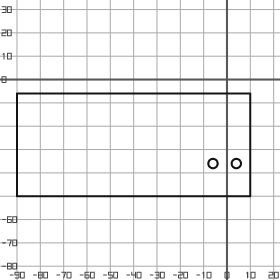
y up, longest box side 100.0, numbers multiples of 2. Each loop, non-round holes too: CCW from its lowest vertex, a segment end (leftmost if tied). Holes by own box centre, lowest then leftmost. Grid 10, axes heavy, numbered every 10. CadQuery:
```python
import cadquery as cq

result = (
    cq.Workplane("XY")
    .moveTo(-90.0, -50.0)
    .lineTo(10.0, -50.0)
    .lineTo(10.0, -6.0)
    .lineTo(-90.0, -6.0)
    .close()
    .moveTo(-6.0, -36.0)
    .circle(2.0)
    .moveTo(4.0, -36.0)
    .circle(2.0)
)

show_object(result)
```